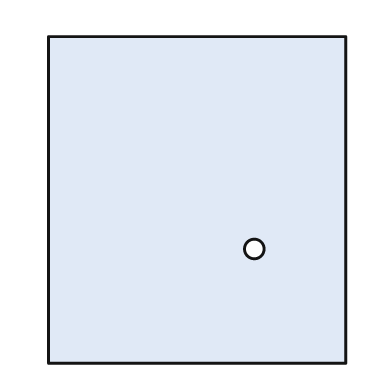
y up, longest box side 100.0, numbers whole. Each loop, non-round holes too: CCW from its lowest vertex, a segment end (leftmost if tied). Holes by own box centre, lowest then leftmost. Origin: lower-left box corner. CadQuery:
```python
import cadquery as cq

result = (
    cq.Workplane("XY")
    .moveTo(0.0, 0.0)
    .lineTo(91.0, 0.0)
    .lineTo(91.0, 100.0)
    .lineTo(0.0, 100.0)
    .close()
    .moveTo(63.0, 35.0)
    .circle(3.0)
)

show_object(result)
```